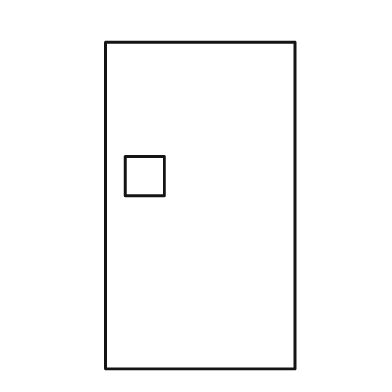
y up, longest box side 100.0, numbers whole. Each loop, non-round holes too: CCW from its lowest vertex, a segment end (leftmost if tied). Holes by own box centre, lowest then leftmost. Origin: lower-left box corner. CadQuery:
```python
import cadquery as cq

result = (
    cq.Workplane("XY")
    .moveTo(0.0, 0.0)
    .lineTo(58.0, 0.0)
    .lineTo(58.0, 100.0)
    .lineTo(0.0, 100.0)
    .close()
    .moveTo(6.0, 53.0)
    .lineTo(18.0, 53.0)
    .lineTo(18.0, 65.0)
    .lineTo(6.0, 65.0)
    .close()
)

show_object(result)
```